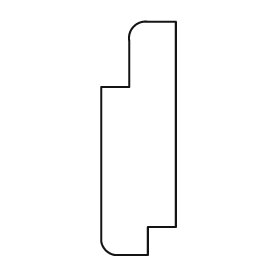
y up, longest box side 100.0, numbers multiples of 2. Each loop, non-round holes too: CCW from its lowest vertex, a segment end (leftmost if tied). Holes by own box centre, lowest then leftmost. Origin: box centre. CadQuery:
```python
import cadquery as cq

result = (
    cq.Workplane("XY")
    .moveTo(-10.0, -50.0)
    .lineTo(4.0, -50.0)
    .lineTo(4.0, -38.0)
    .lineTo(16.0, -38.0)
    .lineTo(16.0, 50.0)
    .lineTo(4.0, 50.0)
    .threePointArc((-2.0, 48.0), (-4.0, 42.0))
    .lineTo(-4.0, 22.0)
    .lineTo(-16.0, 22.0)
    .lineTo(-16.0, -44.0)
    .threePointArc((-14.0, -48.0), (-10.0, -50.0))
    .close()
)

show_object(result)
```